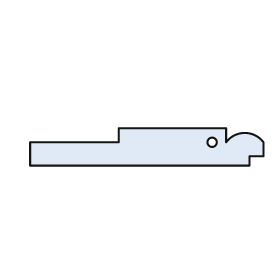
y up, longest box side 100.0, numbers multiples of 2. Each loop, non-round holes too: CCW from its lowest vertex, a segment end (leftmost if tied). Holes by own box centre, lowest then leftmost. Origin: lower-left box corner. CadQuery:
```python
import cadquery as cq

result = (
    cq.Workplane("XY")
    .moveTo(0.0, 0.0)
    .lineTo(94.0, 0.0)
    .lineTo(94.0, 4.0)
    .lineTo(100.0, 4.0)
    .lineTo(100.0, 10.0)
    .threePointArc((92.0, 14.0), (84.0, 10.0))
    .lineTo(84.0, 16.0)
    .lineTo(38.0, 16.0)
    .lineTo(38.0, 10.0)
    .lineTo(0.0, 10.0)
    .close()
    .moveTo(78.0, 10.0)
    .circle(2.0)
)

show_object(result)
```